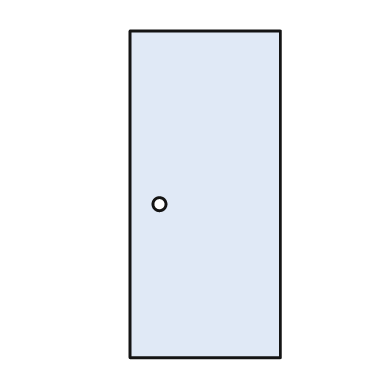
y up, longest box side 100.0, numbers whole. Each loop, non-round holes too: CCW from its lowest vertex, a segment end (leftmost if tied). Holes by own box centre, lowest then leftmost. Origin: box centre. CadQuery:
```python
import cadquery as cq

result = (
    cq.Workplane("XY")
    .moveTo(-23.0, -50.0)
    .lineTo(23.0, -50.0)
    .lineTo(23.0, 50.0)
    .lineTo(-23.0, 50.0)
    .close()
    .moveTo(-14.0, -3.0)
    .circle(2.0)
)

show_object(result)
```